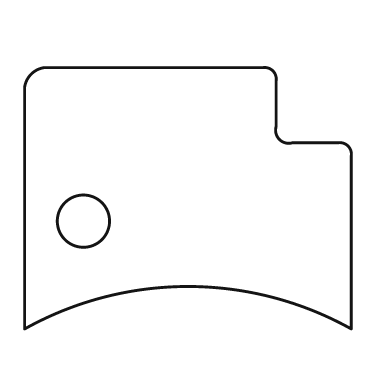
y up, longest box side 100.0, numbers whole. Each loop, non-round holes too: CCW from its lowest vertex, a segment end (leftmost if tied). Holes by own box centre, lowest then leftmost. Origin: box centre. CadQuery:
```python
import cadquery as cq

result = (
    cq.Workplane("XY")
    .moveTo(-50.0, -40.0)
    .threePointArc((0.0, -27.0), (50.0, -40.0))
    .lineTo(50.0, 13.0)
    .threePointArc((49.0, 16.0), (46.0, 17.0))
    .lineTo(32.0, 17.0)
    .threePointArc((28.0, 18.0), (27.0, 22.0))
    .lineTo(27.0, 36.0)
    .threePointArc((26.0, 39.0), (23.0, 40.0))
    .lineTo(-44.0, 40.0)
    .threePointArc((-48.0, 38.0), (-50.0, 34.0))
    .close()
    .moveTo(-32.0, -7.0)
    .circle(8.0)
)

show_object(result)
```